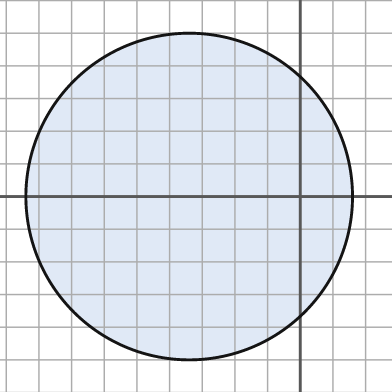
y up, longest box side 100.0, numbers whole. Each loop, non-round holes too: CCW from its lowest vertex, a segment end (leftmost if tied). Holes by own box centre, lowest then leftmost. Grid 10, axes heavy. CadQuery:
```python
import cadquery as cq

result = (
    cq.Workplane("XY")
    .moveTo(-34.0, 0.0)
    .circle(50.0)
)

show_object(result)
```